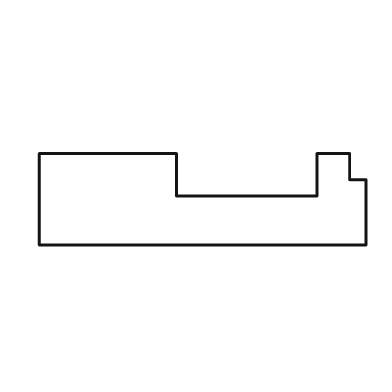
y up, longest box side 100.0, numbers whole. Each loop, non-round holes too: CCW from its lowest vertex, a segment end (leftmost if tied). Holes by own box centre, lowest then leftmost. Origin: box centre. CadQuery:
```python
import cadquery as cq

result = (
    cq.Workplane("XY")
    .moveTo(-50.0, -14.0)
    .lineTo(50.0, -14.0)
    .lineTo(50.0, 6.0)
    .lineTo(45.0, 6.0)
    .lineTo(45.0, 14.0)
    .lineTo(35.0, 14.0)
    .lineTo(35.0, 1.0)
    .lineTo(-8.0, 1.0)
    .lineTo(-8.0, 14.0)
    .lineTo(-50.0, 14.0)
    .close()
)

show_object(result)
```